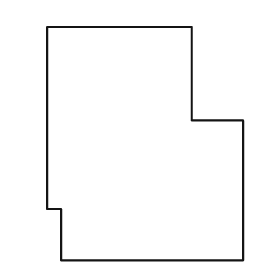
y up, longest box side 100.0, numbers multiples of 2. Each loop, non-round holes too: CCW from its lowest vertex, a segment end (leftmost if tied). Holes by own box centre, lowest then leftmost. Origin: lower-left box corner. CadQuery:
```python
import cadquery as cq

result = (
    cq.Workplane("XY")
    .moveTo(6.0, 0.0)
    .lineTo(84.0, 0.0)
    .lineTo(84.0, 60.0)
    .lineTo(62.0, 60.0)
    .lineTo(62.0, 100.0)
    .lineTo(0.0, 100.0)
    .lineTo(0.0, 22.0)
    .lineTo(6.0, 22.0)
    .close()
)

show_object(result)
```